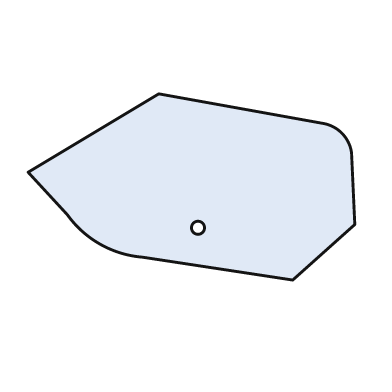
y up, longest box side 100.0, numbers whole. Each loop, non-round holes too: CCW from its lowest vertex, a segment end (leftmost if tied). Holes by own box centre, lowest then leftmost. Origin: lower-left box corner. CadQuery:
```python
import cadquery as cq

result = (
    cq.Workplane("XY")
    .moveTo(81.0, 0.0)
    .lineTo(100.0, 17.0)
    .lineTo(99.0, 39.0)
    .threePointArc((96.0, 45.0), (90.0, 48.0))
    .lineTo(40.0, 57.0)
    .lineTo(0.0, 33.0)
    .lineTo(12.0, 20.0)
    .threePointArc((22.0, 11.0), (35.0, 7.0))
    .close()
    .moveTo(52.0, 16.0)
    .circle(2.0)
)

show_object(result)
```